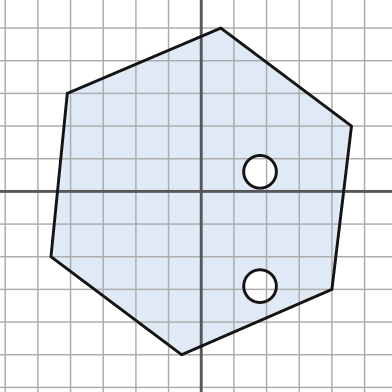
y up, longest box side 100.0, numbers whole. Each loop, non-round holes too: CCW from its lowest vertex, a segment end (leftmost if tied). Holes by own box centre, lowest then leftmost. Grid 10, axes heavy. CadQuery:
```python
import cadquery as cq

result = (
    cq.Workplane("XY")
    .moveTo(-6.0, -50.0)
    .lineTo(40.0, -30.0)
    .lineTo(46.0, 20.0)
    .lineTo(6.0, 50.0)
    .lineTo(-41.0, 30.0)
    .lineTo(-46.0, -20.0)
    .close()
    .moveTo(18.0, -29.0)
    .circle(5.0)
    .moveTo(18.0, 6.0)
    .circle(5.0)
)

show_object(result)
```